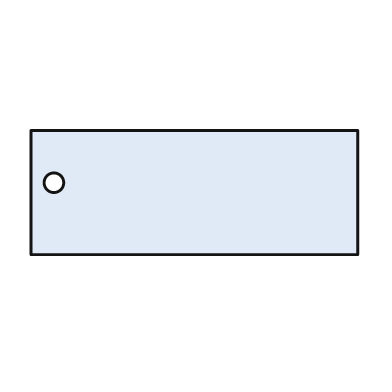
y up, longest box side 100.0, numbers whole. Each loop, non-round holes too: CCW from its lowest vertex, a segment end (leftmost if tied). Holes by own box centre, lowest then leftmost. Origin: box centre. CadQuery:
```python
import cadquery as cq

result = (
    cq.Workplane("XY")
    .moveTo(-50.0, -19.0)
    .lineTo(50.0, -19.0)
    .lineTo(50.0, 19.0)
    .lineTo(-50.0, 19.0)
    .close()
    .moveTo(-43.0, 3.0)
    .circle(3.0)
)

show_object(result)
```